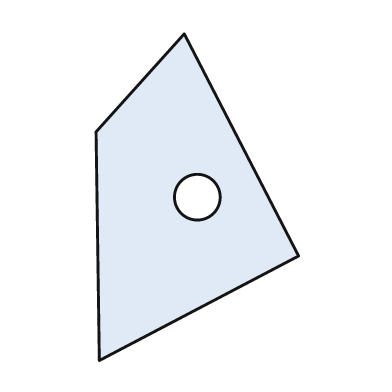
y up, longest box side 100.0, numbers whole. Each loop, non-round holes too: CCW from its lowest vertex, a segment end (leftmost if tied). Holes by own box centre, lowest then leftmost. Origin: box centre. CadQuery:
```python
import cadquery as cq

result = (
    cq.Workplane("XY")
    .moveTo(-30.0, -50.0)
    .lineTo(31.0, -18.0)
    .lineTo(-4.0, 50.0)
    .lineTo(-31.0, 20.0)
    .close()
    .moveTo(0.0, 0.0)
    .circle(7.0)
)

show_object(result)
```